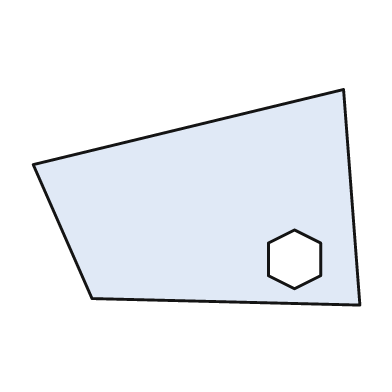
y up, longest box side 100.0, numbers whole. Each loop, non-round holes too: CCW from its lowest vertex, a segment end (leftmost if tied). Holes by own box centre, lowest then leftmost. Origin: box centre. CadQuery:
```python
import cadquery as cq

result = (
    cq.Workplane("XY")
    .moveTo(50.0, -33.0)
    .lineTo(45.0, 33.0)
    .lineTo(-50.0, 10.0)
    .lineTo(-32.0, -31.0)
    .close()
    .moveTo(30.0, -28.0)
    .lineTo(38.0, -24.0)
    .lineTo(38.0, -14.0)
    .lineTo(30.0, -10.0)
    .lineTo(22.0, -14.0)
    .lineTo(22.0, -24.0)
    .close()
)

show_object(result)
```